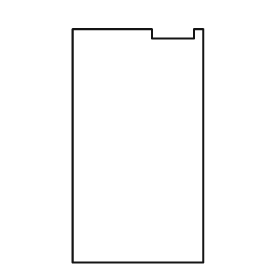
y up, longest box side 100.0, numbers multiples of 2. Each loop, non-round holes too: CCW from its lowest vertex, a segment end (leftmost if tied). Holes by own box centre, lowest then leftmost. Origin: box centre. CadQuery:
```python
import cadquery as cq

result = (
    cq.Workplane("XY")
    .moveTo(-28.0, -50.0)
    .lineTo(28.0, -50.0)
    .lineTo(28.0, 50.0)
    .lineTo(24.0, 50.0)
    .lineTo(24.0, 46.0)
    .lineTo(6.0, 46.0)
    .lineTo(6.0, 50.0)
    .lineTo(-28.0, 50.0)
    .close()
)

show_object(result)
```